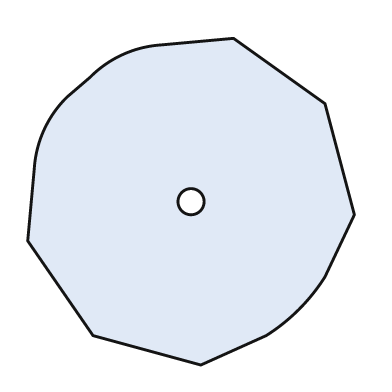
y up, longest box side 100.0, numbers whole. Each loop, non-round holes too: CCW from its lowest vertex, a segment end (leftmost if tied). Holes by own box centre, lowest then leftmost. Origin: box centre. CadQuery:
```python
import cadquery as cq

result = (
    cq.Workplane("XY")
    .moveTo(3.0, -50.0)
    .lineTo(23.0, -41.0)
    .threePointArc((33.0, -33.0), (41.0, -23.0))
    .lineTo(50.0, -4.0)
    .lineTo(41.0, 30.0)
    .lineTo(13.0, 50.0)
    .lineTo(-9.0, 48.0)
    .threePointArc((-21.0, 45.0), (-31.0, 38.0))
    .lineTo(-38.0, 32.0)
    .threePointArc((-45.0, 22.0), (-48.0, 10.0))
    .lineTo(-50.0, -12.0)
    .lineTo(-30.0, -41.0)
    .close()
    .moveTo(0.0, 0.0)
    .circle(4.0)
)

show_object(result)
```